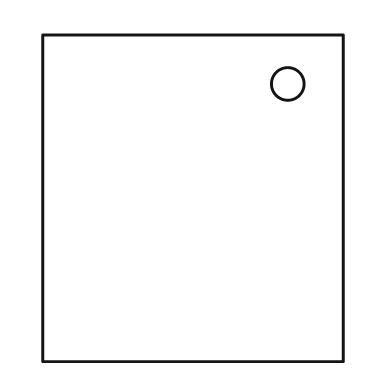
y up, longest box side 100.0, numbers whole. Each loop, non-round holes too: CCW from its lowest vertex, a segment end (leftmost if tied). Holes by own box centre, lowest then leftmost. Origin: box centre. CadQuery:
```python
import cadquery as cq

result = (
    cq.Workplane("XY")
    .moveTo(-46.0, -50.0)
    .lineTo(46.0, -50.0)
    .lineTo(46.0, 50.0)
    .lineTo(-46.0, 50.0)
    .close()
    .moveTo(29.0, 35.0)
    .circle(5.0)
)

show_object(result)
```